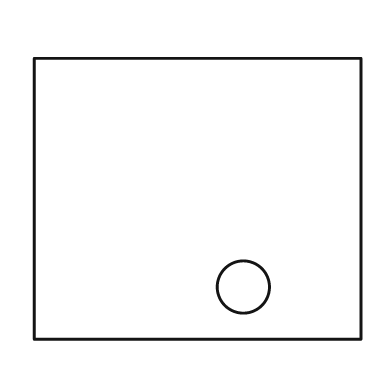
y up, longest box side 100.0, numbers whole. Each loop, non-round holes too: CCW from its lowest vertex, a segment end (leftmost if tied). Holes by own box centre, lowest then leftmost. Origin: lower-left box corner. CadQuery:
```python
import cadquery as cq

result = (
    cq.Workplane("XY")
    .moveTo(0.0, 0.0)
    .lineTo(100.0, 0.0)
    .lineTo(100.0, 86.0)
    .lineTo(0.0, 86.0)
    .close()
    .moveTo(64.0, 16.0)
    .circle(8.0)
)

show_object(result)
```